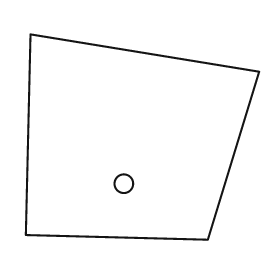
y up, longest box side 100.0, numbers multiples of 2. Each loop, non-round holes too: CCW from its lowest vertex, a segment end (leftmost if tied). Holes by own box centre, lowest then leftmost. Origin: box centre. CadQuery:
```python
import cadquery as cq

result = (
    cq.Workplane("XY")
    .moveTo(28.0, -44.0)
    .lineTo(50.0, 28.0)
    .lineTo(-48.0, 44.0)
    .lineTo(-50.0, -42.0)
    .close()
    .moveTo(-8.0, -20.0)
    .circle(4.0)
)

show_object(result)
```